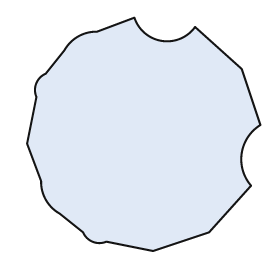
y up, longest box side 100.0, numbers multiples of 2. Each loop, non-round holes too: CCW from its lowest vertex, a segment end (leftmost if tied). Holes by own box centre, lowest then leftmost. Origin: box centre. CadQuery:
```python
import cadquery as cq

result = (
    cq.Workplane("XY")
    .moveTo(4.0, -50.0)
    .lineTo(28.0, -42.0)
    .lineTo(46.0, -22.0)
    .threePointArc((42.0, -8.0), (50.0, 4.0))
    .lineTo(42.0, 28.0)
    .lineTo(22.0, 46.0)
    .threePointArc((8.0, 40.0), (-4.0, 50.0))
    .lineTo(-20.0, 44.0)
    .threePointArc((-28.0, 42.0), (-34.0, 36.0))
    .lineTo(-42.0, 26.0)
    .threePointArc((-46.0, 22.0), (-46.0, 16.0))
    .lineTo(-50.0, -4.0)
    .lineTo(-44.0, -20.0)
    .threePointArc((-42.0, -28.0), (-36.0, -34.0))
    .lineTo(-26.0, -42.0)
    .threePointArc((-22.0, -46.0), (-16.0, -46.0))
    .close()
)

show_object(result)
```